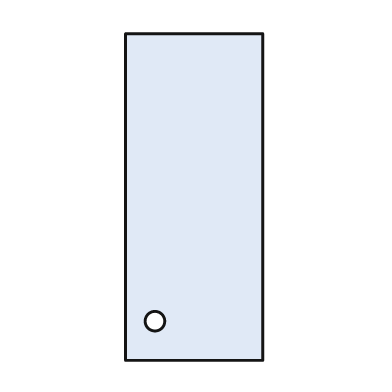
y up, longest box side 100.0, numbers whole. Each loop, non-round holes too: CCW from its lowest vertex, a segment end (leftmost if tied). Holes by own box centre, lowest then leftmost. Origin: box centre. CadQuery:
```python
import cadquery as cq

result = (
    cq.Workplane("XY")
    .moveTo(-21.0, -50.0)
    .lineTo(21.0, -50.0)
    .lineTo(21.0, 50.0)
    .lineTo(-21.0, 50.0)
    .close()
    .moveTo(-12.0, -38.0)
    .circle(3.0)
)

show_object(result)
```